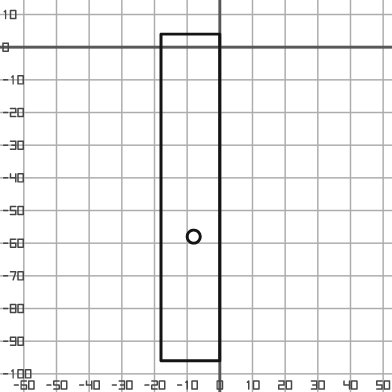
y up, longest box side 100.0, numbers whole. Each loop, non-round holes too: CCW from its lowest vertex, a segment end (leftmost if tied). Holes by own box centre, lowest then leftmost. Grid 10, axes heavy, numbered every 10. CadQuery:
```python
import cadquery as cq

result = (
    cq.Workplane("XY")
    .moveTo(-18.0, -96.0)
    .lineTo(0.0, -96.0)
    .lineTo(0.0, 4.0)
    .lineTo(-18.0, 4.0)
    .close()
    .moveTo(-8.0, -58.0)
    .circle(2.0)
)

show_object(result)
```